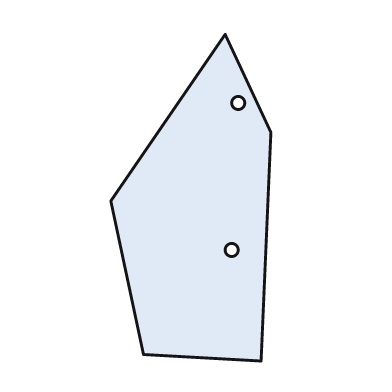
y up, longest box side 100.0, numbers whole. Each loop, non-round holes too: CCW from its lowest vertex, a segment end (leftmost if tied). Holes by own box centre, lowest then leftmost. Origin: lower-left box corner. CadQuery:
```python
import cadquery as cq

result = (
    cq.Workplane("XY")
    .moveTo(46.0, 0.0)
    .lineTo(49.0, 70.0)
    .lineTo(35.0, 100.0)
    .lineTo(0.0, 49.0)
    .lineTo(10.0, 2.0)
    .close()
    .moveTo(37.0, 34.0)
    .circle(2.0)
    .moveTo(39.0, 79.0)
    .circle(2.0)
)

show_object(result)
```